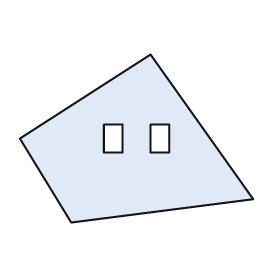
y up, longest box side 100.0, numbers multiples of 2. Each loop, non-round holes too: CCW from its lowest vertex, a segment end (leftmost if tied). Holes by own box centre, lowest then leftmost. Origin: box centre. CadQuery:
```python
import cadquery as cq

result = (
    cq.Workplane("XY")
    .moveTo(-28.0, -36.0)
    .lineTo(50.0, -26.0)
    .lineTo(6.0, 36.0)
    .lineTo(-50.0, 0.0)
    .close()
    .moveTo(-14.0, -6.0)
    .lineTo(-6.0, -6.0)
    .lineTo(-6.0, 6.0)
    .lineTo(-14.0, 6.0)
    .close()
    .moveTo(6.0, -6.0)
    .lineTo(14.0, -6.0)
    .lineTo(14.0, 6.0)
    .lineTo(6.0, 6.0)
    .close()
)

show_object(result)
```